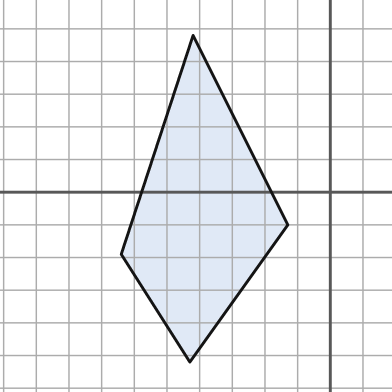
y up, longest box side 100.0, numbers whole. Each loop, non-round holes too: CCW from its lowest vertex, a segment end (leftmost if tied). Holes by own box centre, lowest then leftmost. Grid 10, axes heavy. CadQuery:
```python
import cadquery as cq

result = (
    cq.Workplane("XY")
    .moveTo(-43.0, -52.0)
    .lineTo(-13.0, -10.0)
    .lineTo(-42.0, 48.0)
    .lineTo(-64.0, -19.0)
    .close()
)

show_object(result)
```